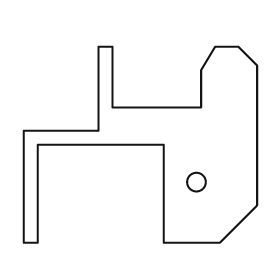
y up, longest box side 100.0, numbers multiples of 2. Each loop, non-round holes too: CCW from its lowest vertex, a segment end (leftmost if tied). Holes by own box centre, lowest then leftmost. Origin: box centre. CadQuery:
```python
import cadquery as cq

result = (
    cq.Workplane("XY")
    .moveTo(-50.0, -42.0)
    .lineTo(-44.0, -42.0)
    .lineTo(-44.0, 0.0)
    .lineTo(10.0, 0.0)
    .lineTo(10.0, -42.0)
    .lineTo(34.0, -42.0)
    .lineTo(50.0, -26.0)
    .lineTo(50.0, 34.0)
    .lineTo(42.0, 42.0)
    .lineTo(32.0, 42.0)
    .lineTo(26.0, 32.0)
    .lineTo(26.0, 16.0)
    .lineTo(-12.0, 16.0)
    .lineTo(-12.0, 42.0)
    .lineTo(-18.0, 42.0)
    .lineTo(-18.0, 6.0)
    .lineTo(-50.0, 6.0)
    .close()
    .moveTo(24.0, -16.0)
    .circle(4.0)
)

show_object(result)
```